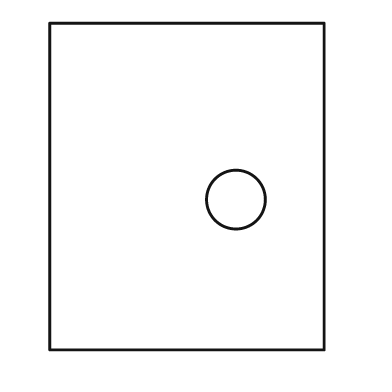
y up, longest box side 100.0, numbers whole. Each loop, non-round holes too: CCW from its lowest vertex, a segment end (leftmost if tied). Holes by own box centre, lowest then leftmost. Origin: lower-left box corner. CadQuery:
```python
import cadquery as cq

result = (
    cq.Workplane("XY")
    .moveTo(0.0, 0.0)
    .lineTo(84.0, 0.0)
    .lineTo(84.0, 100.0)
    .lineTo(0.0, 100.0)
    .close()
    .moveTo(57.0, 46.0)
    .circle(9.0)
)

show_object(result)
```